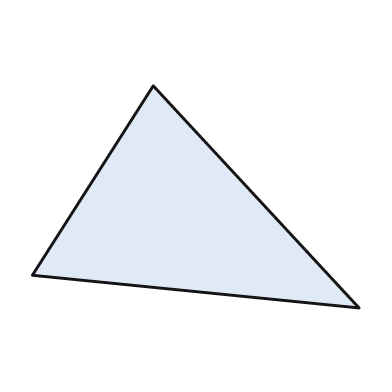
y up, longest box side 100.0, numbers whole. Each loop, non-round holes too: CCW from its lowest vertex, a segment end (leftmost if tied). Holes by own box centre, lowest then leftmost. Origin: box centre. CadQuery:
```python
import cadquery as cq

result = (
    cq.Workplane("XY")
    .moveTo(50.0, -34.0)
    .lineTo(-13.0, 34.0)
    .lineTo(-50.0, -24.0)
    .close()
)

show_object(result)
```